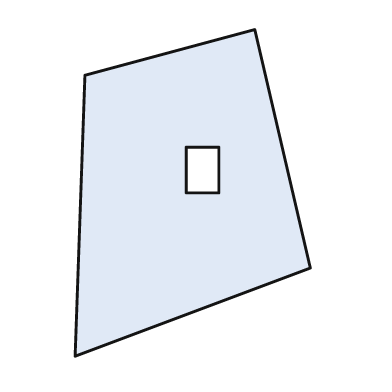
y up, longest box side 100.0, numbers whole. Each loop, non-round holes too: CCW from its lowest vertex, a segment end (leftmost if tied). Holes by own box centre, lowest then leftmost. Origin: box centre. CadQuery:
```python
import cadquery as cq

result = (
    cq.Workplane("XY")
    .moveTo(-36.0, -50.0)
    .lineTo(36.0, -23.0)
    .lineTo(19.0, 50.0)
    .lineTo(-33.0, 36.0)
    .close()
    .moveTo(-2.0, 0.0)
    .lineTo(8.0, 0.0)
    .lineTo(8.0, 14.0)
    .lineTo(-2.0, 14.0)
    .close()
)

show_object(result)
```